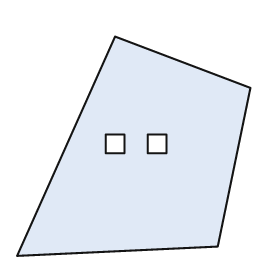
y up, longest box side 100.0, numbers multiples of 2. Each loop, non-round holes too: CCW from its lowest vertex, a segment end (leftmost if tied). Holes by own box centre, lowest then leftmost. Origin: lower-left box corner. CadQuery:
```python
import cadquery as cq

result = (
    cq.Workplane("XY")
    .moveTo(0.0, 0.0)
    .lineTo(86.0, 4.0)
    .lineTo(100.0, 72.0)
    .lineTo(42.0, 94.0)
    .close()
    .moveTo(38.0, 44.0)
    .lineTo(46.0, 44.0)
    .lineTo(46.0, 52.0)
    .lineTo(38.0, 52.0)
    .close()
    .moveTo(56.0, 44.0)
    .lineTo(64.0, 44.0)
    .lineTo(64.0, 52.0)
    .lineTo(56.0, 52.0)
    .close()
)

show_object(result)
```